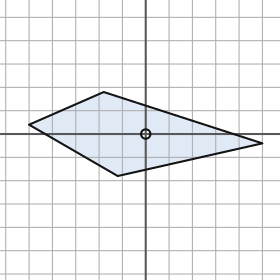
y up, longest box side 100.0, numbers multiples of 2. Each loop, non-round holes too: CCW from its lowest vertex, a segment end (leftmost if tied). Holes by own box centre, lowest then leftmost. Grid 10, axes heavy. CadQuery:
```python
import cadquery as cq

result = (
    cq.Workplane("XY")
    .moveTo(-12.0, -18.0)
    .lineTo(50.0, -4.0)
    .lineTo(-18.0, 18.0)
    .lineTo(-50.0, 4.0)
    .close()
    .moveTo(0.0, 0.0)
    .circle(2.0)
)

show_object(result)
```